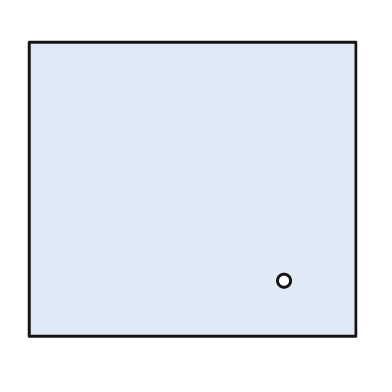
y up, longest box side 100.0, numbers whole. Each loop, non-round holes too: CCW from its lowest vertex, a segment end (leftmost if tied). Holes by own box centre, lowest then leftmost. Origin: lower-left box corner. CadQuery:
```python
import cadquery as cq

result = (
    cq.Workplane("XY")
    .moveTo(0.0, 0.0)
    .lineTo(100.0, 0.0)
    .lineTo(100.0, 90.0)
    .lineTo(0.0, 90.0)
    .close()
    .moveTo(78.0, 17.0)
    .circle(2.0)
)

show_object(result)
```